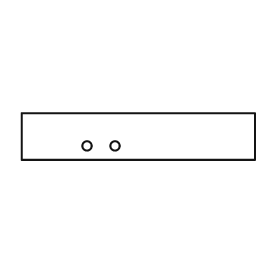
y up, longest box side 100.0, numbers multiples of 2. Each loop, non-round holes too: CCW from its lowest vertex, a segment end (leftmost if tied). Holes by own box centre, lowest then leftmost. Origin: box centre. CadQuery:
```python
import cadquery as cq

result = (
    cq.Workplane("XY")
    .moveTo(-50.0, -10.0)
    .lineTo(50.0, -10.0)
    .lineTo(50.0, 10.0)
    .lineTo(-50.0, 10.0)
    .close()
    .moveTo(-22.0, -4.0)
    .circle(2.0)
    .moveTo(-10.0, -4.0)
    .circle(2.0)
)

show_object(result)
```